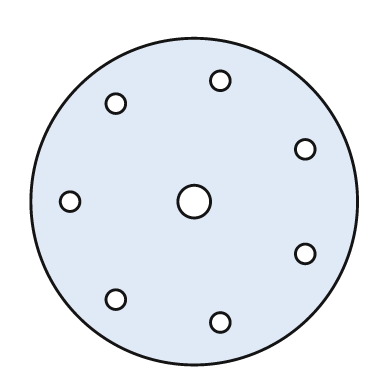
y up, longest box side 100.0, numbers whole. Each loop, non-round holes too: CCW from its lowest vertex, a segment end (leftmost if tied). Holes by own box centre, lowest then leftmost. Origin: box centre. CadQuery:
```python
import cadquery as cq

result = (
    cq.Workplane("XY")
    .moveTo(0.0, 0.0)
    .circle(50.0)
    .moveTo(8.0, -37.0)
    .circle(3.0)
    .moveTo(-24.0, -30.0)
    .circle(3.0)
    .moveTo(34.0, -16.0)
    .circle(3.0)
    .moveTo(-38.0, 0.0)
    .circle(3.0)
    .moveTo(0.0, 0.0)
    .circle(5.0)
    .moveTo(34.0, 16.0)
    .circle(3.0)
    .moveTo(-24.0, 30.0)
    .circle(3.0)
    .moveTo(8.0, 37.0)
    .circle(3.0)
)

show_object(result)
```